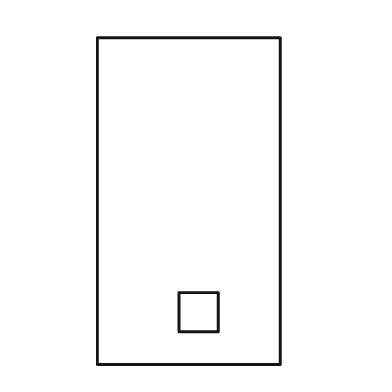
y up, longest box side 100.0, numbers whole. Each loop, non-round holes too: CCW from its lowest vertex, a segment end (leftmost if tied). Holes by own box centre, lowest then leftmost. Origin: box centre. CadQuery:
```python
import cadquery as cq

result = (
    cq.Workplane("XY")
    .moveTo(-28.0, -50.0)
    .lineTo(28.0, -50.0)
    .lineTo(28.0, 50.0)
    .lineTo(-28.0, 50.0)
    .close()
    .moveTo(-3.0, -40.0)
    .lineTo(9.0, -40.0)
    .lineTo(9.0, -28.0)
    .lineTo(-3.0, -28.0)
    .close()
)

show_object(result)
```